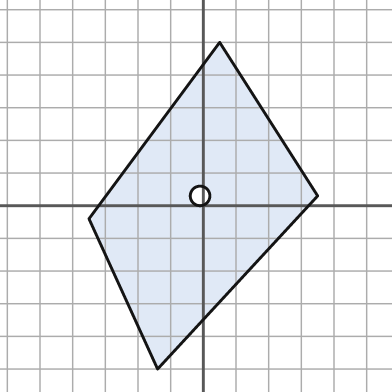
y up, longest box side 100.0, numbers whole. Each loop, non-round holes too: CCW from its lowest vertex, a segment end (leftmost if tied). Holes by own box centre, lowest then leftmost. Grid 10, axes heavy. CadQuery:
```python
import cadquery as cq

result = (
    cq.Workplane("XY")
    .moveTo(-14.0, -50.0)
    .lineTo(35.0, 3.0)
    .lineTo(5.0, 50.0)
    .lineTo(-35.0, -4.0)
    .close()
    .moveTo(-1.0, 3.0)
    .circle(3.0)
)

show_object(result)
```